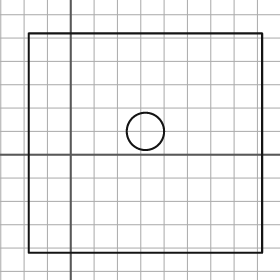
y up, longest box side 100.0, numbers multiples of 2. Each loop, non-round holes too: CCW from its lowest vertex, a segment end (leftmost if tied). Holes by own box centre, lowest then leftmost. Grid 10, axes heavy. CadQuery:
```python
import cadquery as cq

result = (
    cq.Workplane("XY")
    .moveTo(-18.0, -42.0)
    .lineTo(82.0, -42.0)
    .lineTo(82.0, 52.0)
    .lineTo(-18.0, 52.0)
    .close()
    .moveTo(32.0, 10.0)
    .circle(8.0)
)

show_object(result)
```